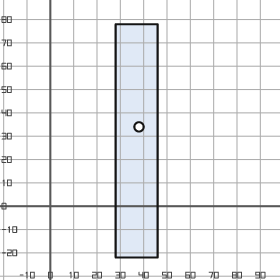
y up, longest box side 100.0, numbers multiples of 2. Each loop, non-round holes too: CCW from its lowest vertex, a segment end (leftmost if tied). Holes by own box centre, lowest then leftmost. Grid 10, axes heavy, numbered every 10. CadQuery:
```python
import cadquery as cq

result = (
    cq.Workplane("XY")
    .moveTo(28.0, -22.0)
    .lineTo(46.0, -22.0)
    .lineTo(46.0, 78.0)
    .lineTo(28.0, 78.0)
    .close()
    .moveTo(38.0, 34.0)
    .circle(2.0)
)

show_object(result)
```